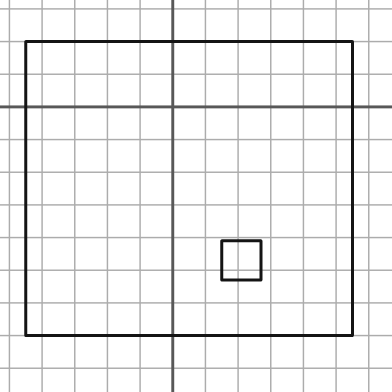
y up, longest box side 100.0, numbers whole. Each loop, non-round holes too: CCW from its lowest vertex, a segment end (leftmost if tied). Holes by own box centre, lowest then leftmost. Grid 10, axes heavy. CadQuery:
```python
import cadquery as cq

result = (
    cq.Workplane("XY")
    .moveTo(-45.0, -70.0)
    .lineTo(55.0, -70.0)
    .lineTo(55.0, 20.0)
    .lineTo(-45.0, 20.0)
    .close()
    .moveTo(15.0, -53.0)
    .lineTo(27.0, -53.0)
    .lineTo(27.0, -41.0)
    .lineTo(15.0, -41.0)
    .close()
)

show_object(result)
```